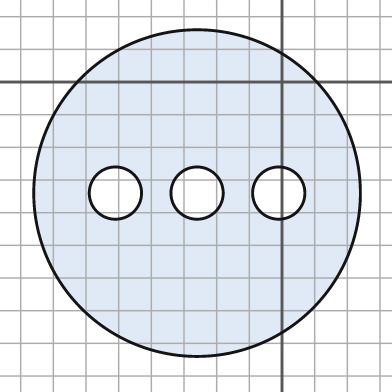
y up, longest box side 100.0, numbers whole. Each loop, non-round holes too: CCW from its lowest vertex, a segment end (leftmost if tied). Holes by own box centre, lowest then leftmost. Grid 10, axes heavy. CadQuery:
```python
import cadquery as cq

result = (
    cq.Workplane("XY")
    .moveTo(-26.0, -34.0)
    .circle(50.0)
    .moveTo(-51.0, -34.0)
    .circle(8.0)
    .moveTo(-26.0, -34.0)
    .circle(8.0)
    .moveTo(-1.0, -34.0)
    .circle(8.0)
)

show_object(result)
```